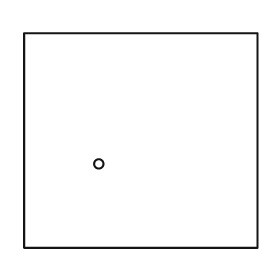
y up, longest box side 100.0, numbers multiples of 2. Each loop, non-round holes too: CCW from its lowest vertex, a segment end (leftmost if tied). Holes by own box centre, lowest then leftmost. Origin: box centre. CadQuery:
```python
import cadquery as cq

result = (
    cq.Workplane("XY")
    .moveTo(-50.0, -46.0)
    .lineTo(50.0, -46.0)
    .lineTo(50.0, 46.0)
    .lineTo(-50.0, 46.0)
    .close()
    .moveTo(-18.0, -10.0)
    .circle(2.0)
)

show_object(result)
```